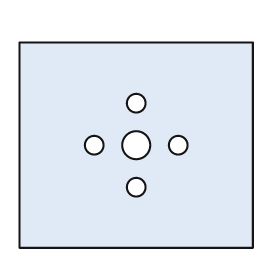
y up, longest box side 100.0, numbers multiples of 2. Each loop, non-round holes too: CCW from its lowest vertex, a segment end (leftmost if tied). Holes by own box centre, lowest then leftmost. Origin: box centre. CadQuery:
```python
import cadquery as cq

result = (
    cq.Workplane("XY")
    .moveTo(-50.0, -44.0)
    .lineTo(50.0, -44.0)
    .lineTo(50.0, 44.0)
    .lineTo(-50.0, 44.0)
    .close()
    .moveTo(0.0, -18.0)
    .circle(4.0)
    .moveTo(-18.0, 0.0)
    .circle(4.0)
    .moveTo(0.0, 0.0)
    .circle(6.0)
    .moveTo(18.0, 0.0)
    .circle(4.0)
    .moveTo(0.0, 18.0)
    .circle(4.0)
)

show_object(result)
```